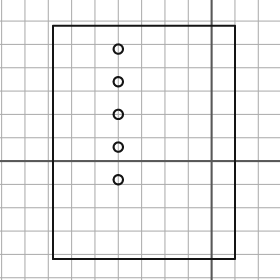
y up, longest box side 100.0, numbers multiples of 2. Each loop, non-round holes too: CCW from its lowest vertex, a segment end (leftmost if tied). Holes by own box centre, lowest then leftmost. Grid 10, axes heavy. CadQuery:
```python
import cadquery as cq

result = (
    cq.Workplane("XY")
    .moveTo(-68.0, -42.0)
    .lineTo(10.0, -42.0)
    .lineTo(10.0, 58.0)
    .lineTo(-68.0, 58.0)
    .close()
    .moveTo(-40.0, -8.0)
    .circle(2.0)
    .moveTo(-40.0, 6.0)
    .circle(2.0)
    .moveTo(-40.0, 20.0)
    .circle(2.0)
    .moveTo(-40.0, 34.0)
    .circle(2.0)
    .moveTo(-40.0, 48.0)
    .circle(2.0)
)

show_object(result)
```